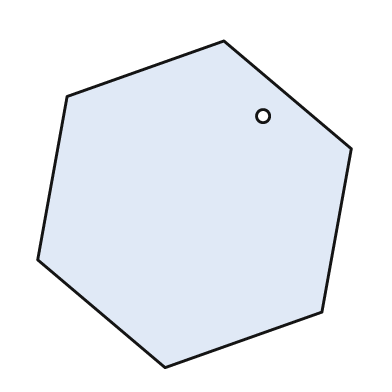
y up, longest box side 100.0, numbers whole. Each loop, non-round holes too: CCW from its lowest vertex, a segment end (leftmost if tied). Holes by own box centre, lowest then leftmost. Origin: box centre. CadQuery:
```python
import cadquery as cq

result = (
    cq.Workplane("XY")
    .moveTo(-9.0, -50.0)
    .lineTo(39.0, -33.0)
    .lineTo(48.0, 17.0)
    .lineTo(9.0, 50.0)
    .lineTo(-39.0, 33.0)
    .lineTo(-48.0, -17.0)
    .close()
    .moveTo(21.0, 27.0)
    .circle(2.0)
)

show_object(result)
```